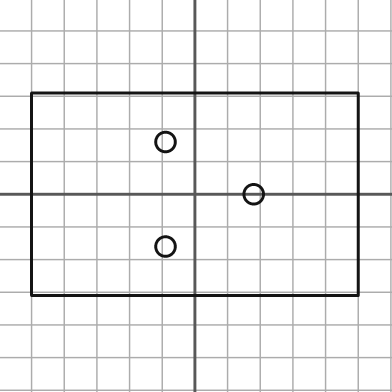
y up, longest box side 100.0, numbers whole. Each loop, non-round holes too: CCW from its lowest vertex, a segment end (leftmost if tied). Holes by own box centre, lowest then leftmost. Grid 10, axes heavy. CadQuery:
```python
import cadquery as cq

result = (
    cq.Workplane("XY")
    .moveTo(-50.0, -31.0)
    .lineTo(50.0, -31.0)
    .lineTo(50.0, 31.0)
    .lineTo(-50.0, 31.0)
    .close()
    .moveTo(-9.0, -16.0)
    .circle(3.0)
    .moveTo(18.0, 0.0)
    .circle(3.0)
    .moveTo(-9.0, 16.0)
    .circle(3.0)
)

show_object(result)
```